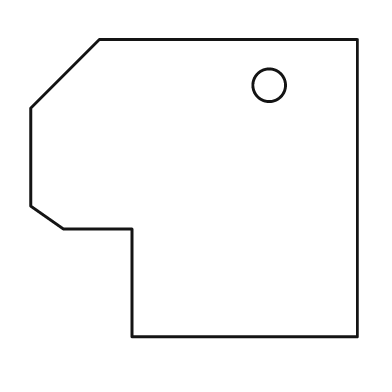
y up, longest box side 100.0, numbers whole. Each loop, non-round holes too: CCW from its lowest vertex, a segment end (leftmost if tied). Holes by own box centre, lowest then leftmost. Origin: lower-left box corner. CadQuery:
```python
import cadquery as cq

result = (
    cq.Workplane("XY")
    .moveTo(31.0, 0.0)
    .lineTo(100.0, 0.0)
    .lineTo(100.0, 91.0)
    .lineTo(21.0, 91.0)
    .lineTo(0.0, 70.0)
    .lineTo(0.0, 40.0)
    .lineTo(10.0, 33.0)
    .lineTo(31.0, 33.0)
    .close()
    .moveTo(73.0, 77.0)
    .circle(5.0)
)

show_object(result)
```